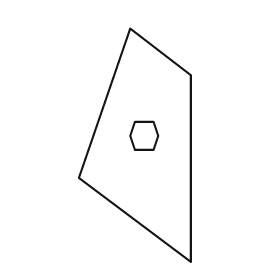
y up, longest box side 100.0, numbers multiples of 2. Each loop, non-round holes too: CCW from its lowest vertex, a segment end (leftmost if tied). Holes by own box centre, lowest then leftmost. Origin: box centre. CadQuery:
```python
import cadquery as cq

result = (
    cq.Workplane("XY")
    .moveTo(24.0, -50.0)
    .lineTo(24.0, 30.0)
    .lineTo(-2.0, 50.0)
    .lineTo(-24.0, -14.0)
    .close()
    .moveTo(0.0, -2.0)
    .lineTo(8.0, -2.0)
    .lineTo(10.0, 4.0)
    .lineTo(8.0, 10.0)
    .lineTo(0.0, 10.0)
    .lineTo(-2.0, 4.0)
    .close()
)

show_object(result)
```